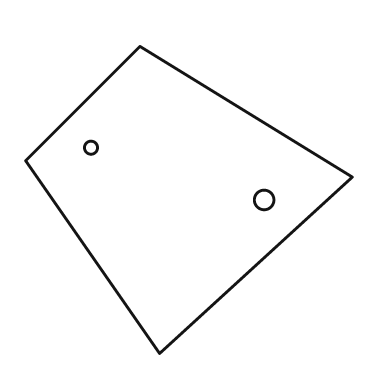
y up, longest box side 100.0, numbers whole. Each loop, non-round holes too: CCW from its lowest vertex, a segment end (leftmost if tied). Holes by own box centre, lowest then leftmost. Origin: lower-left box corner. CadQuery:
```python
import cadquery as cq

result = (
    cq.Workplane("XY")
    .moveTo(41.0, 0.0)
    .lineTo(100.0, 54.0)
    .lineTo(35.0, 94.0)
    .lineTo(0.0, 59.0)
    .close()
    .moveTo(73.0, 47.0)
    .circle(3.0)
    .moveTo(20.0, 63.0)
    .circle(2.0)
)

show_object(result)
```